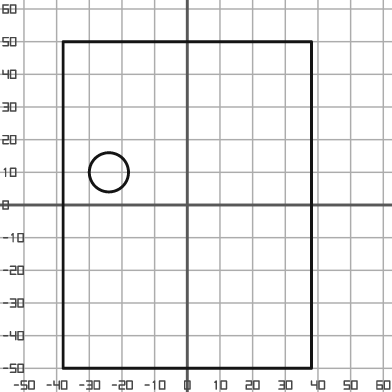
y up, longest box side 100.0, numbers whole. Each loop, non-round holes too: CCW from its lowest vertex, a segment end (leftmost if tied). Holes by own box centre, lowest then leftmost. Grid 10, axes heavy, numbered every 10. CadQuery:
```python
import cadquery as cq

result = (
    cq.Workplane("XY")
    .moveTo(-38.0, -50.0)
    .lineTo(38.0, -50.0)
    .lineTo(38.0, 50.0)
    .lineTo(-38.0, 50.0)
    .close()
    .moveTo(-24.0, 10.0)
    .circle(6.0)
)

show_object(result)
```